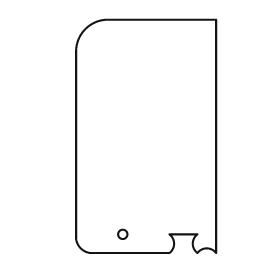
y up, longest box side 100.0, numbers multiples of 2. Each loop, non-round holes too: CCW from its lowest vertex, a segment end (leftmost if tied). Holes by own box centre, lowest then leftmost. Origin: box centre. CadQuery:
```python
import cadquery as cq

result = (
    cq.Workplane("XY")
    .moveTo(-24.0, -50.0)
    .lineTo(10.0, -50.0)
    .threePointArc((12.0, -46.0), (10.0, -42.0))
    .lineTo(22.0, -42.0)
    .threePointArc((20.0, -46.0), (22.0, -50.0))
    .threePointArc((26.0, -48.0), (30.0, -50.0))
    .lineTo(30.0, 50.0)
    .lineTo(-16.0, 50.0)
    .threePointArc((-26.0, 46.0), (-30.0, 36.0))
    .lineTo(-30.0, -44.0)
    .threePointArc((-28.0, -48.0), (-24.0, -50.0))
    .close()
    .moveTo(-10.0, -42.0)
    .circle(2.0)
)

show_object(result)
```